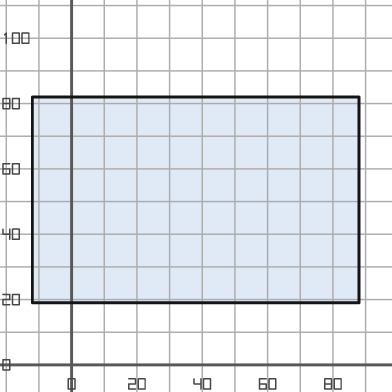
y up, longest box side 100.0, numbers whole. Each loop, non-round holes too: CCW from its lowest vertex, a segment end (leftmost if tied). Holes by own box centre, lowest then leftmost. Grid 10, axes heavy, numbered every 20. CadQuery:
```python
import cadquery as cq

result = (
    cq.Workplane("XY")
    .moveTo(-12.0, 19.0)
    .lineTo(88.0, 19.0)
    .lineTo(88.0, 82.0)
    .lineTo(-12.0, 82.0)
    .close()
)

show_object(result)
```